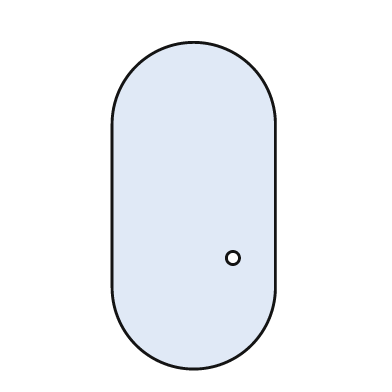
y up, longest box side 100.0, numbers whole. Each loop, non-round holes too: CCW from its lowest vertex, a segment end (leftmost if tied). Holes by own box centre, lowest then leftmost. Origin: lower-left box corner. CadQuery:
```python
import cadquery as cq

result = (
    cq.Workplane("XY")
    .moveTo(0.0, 25.0)
    .threePointArc((25.0, 0.0), (50.0, 25.0))
    .lineTo(50.0, 75.0)
    .threePointArc((25.0, 100.0), (0.0, 75.0))
    .close()
    .moveTo(37.0, 34.0)
    .circle(2.0)
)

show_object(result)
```